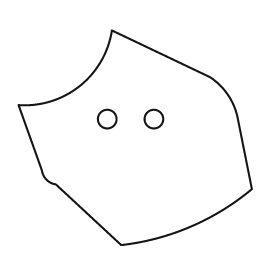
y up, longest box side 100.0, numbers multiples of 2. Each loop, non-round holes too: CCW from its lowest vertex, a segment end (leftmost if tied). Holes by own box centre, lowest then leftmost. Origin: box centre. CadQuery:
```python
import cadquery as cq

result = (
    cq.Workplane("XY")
    .moveTo(-6.0, -46.0)
    .threePointArc((24.0, -38.0), (50.0, -22.0))
    .lineTo(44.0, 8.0)
    .threePointArc((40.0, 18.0), (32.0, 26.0))
    .lineTo(-10.0, 46.0)
    .threePointArc((-24.0, 22.0), (-50.0, 14.0))
    .lineTo(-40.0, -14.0)
    .threePointArc((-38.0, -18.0), (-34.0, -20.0))
    .close()
    .moveTo(-12.0, 8.0)
    .circle(4.0)
    .moveTo(8.0, 8.0)
    .circle(4.0)
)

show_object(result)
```